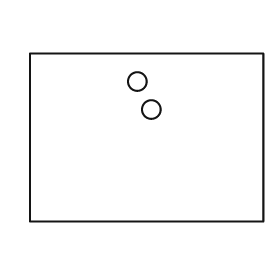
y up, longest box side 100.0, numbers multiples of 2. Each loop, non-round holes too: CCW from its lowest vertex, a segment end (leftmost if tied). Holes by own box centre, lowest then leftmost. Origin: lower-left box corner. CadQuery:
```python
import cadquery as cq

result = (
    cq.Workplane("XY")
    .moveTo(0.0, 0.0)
    .lineTo(100.0, 0.0)
    .lineTo(100.0, 72.0)
    .lineTo(0.0, 72.0)
    .close()
    .moveTo(52.0, 48.0)
    .circle(4.0)
    .moveTo(46.0, 60.0)
    .circle(4.0)
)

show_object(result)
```